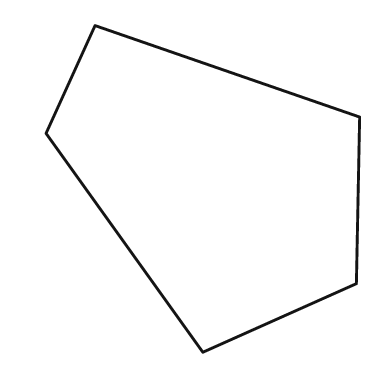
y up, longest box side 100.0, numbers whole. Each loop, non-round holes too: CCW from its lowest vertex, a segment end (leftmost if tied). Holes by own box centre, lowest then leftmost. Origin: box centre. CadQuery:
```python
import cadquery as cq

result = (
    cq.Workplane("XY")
    .moveTo(0.0, -50.0)
    .lineTo(47.0, -29.0)
    .lineTo(48.0, 22.0)
    .lineTo(-33.0, 50.0)
    .lineTo(-48.0, 17.0)
    .close()
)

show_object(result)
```